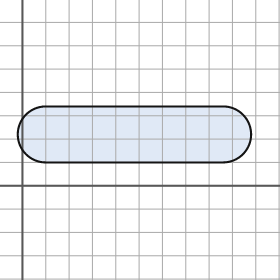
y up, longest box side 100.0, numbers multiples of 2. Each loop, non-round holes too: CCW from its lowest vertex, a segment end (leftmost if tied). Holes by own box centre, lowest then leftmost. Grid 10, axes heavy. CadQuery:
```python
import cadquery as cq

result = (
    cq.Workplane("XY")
    .moveTo(10.0, 10.0)
    .lineTo(86.0, 10.0)
    .threePointArc((98.0, 22.0), (86.0, 34.0))
    .lineTo(10.0, 34.0)
    .threePointArc((-2.0, 22.0), (10.0, 10.0))
    .close()
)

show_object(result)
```